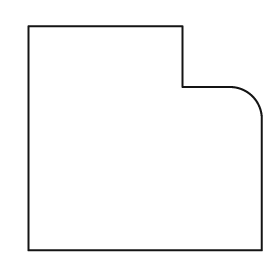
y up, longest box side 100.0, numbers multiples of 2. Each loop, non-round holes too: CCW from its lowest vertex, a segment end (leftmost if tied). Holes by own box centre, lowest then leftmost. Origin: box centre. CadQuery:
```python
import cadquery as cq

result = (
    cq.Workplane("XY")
    .moveTo(-50.0, -48.0)
    .lineTo(50.0, -48.0)
    .lineTo(50.0, 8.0)
    .threePointArc((46.0, 18.0), (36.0, 22.0))
    .lineTo(16.0, 22.0)
    .lineTo(16.0, 48.0)
    .lineTo(-50.0, 48.0)
    .close()
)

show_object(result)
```